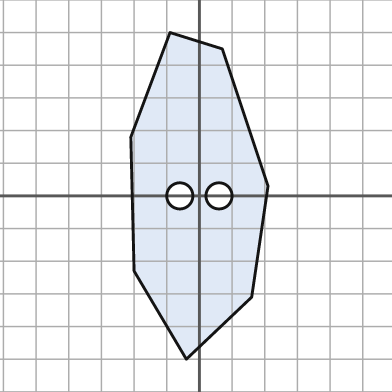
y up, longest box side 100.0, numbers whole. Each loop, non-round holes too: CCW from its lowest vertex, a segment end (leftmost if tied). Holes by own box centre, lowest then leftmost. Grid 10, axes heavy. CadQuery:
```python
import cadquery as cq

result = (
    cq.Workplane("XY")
    .moveTo(-4.0, -50.0)
    .lineTo(16.0, -31.0)
    .lineTo(21.0, 3.0)
    .lineTo(7.0, 45.0)
    .lineTo(-9.0, 50.0)
    .lineTo(-21.0, 18.0)
    .lineTo(-20.0, -23.0)
    .close()
    .moveTo(-6.0, 0.0)
    .circle(4.0)
    .moveTo(6.0, 0.0)
    .circle(4.0)
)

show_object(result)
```